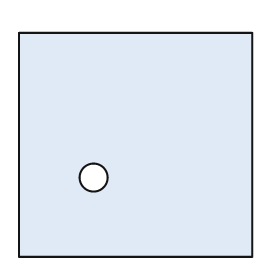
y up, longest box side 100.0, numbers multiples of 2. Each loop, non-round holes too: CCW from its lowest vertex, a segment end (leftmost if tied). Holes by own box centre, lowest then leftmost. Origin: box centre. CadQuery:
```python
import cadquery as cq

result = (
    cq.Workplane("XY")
    .moveTo(-50.0, -48.0)
    .lineTo(50.0, -48.0)
    .lineTo(50.0, 48.0)
    .lineTo(-50.0, 48.0)
    .close()
    .moveTo(-18.0, -14.0)
    .circle(6.0)
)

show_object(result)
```